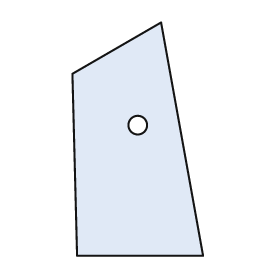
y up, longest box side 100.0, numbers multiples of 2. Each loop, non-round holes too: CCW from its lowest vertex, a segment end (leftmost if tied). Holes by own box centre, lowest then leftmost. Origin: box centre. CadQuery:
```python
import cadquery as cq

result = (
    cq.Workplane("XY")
    .moveTo(-26.0, -50.0)
    .lineTo(28.0, -50.0)
    .lineTo(10.0, 50.0)
    .lineTo(-28.0, 28.0)
    .close()
    .moveTo(0.0, 6.0)
    .circle(4.0)
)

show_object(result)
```